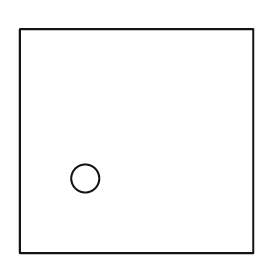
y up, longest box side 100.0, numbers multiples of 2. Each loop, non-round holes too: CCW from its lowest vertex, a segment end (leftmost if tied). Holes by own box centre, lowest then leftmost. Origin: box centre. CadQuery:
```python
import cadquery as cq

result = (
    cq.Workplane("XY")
    .moveTo(-50.0, -48.0)
    .lineTo(50.0, -48.0)
    .lineTo(50.0, 48.0)
    .lineTo(-50.0, 48.0)
    .close()
    .moveTo(-22.0, -16.0)
    .circle(6.0)
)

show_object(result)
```